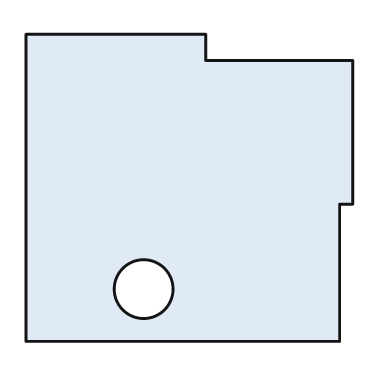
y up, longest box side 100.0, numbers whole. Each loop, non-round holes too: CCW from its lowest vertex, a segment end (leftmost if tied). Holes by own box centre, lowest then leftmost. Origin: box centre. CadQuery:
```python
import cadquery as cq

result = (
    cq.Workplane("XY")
    .moveTo(-50.0, -47.0)
    .lineTo(46.0, -47.0)
    .lineTo(46.0, -5.0)
    .lineTo(50.0, -5.0)
    .lineTo(50.0, 39.0)
    .lineTo(5.0, 39.0)
    .lineTo(5.0, 47.0)
    .lineTo(-50.0, 47.0)
    .close()
    .moveTo(-14.0, -31.0)
    .circle(9.0)
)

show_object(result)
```